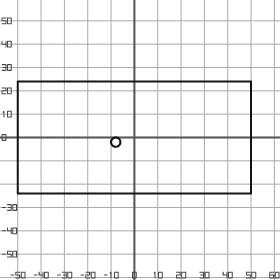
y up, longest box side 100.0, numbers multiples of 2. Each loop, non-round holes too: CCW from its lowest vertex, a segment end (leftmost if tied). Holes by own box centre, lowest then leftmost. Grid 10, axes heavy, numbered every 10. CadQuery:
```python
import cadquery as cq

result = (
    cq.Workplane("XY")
    .moveTo(-50.0, -24.0)
    .lineTo(50.0, -24.0)
    .lineTo(50.0, 24.0)
    .lineTo(-50.0, 24.0)
    .close()
    .moveTo(-8.0, -2.0)
    .circle(2.0)
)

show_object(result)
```